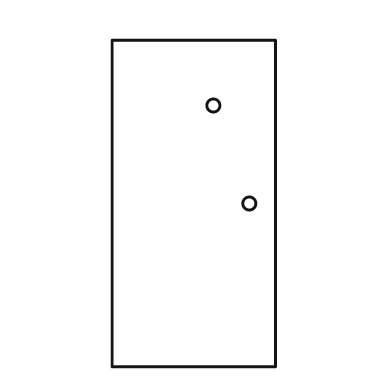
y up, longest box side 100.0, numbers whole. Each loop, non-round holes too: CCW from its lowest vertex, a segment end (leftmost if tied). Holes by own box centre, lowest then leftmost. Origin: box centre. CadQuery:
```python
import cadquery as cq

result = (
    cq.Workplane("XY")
    .moveTo(-25.0, -50.0)
    .lineTo(25.0, -50.0)
    .lineTo(25.0, 50.0)
    .lineTo(-25.0, 50.0)
    .close()
    .moveTo(17.0, 0.0)
    .circle(2.0)
    .moveTo(6.0, 30.0)
    .circle(2.0)
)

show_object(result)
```